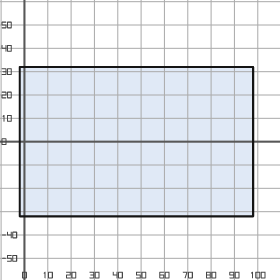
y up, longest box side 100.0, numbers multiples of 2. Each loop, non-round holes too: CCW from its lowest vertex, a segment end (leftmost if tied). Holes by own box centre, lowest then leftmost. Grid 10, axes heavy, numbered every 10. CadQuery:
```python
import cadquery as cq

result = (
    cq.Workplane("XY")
    .moveTo(-2.0, -32.0)
    .lineTo(98.0, -32.0)
    .lineTo(98.0, 32.0)
    .lineTo(-2.0, 32.0)
    .close()
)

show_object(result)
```